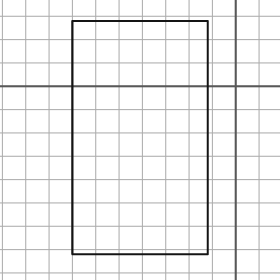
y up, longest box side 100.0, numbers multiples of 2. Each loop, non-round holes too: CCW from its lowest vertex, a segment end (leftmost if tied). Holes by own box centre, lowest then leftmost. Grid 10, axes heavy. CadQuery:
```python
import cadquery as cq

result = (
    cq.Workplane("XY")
    .moveTo(-70.0, -72.0)
    .lineTo(-12.0, -72.0)
    .lineTo(-12.0, 28.0)
    .lineTo(-70.0, 28.0)
    .close()
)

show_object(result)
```